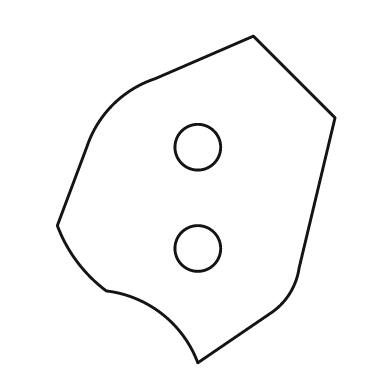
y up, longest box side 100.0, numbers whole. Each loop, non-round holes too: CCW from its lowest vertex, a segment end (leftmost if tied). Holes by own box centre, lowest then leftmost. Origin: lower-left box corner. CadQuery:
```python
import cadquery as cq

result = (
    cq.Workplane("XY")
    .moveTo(43.0, 0.0)
    .lineTo(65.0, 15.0)
    .threePointArc((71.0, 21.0), (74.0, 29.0))
    .lineTo(85.0, 75.0)
    .lineTo(60.0, 100.0)
    .lineTo(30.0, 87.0)
    .threePointArc((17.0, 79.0), (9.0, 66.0))
    .lineTo(0.0, 42.0)
    .threePointArc((6.0, 31.0), (15.0, 22.0))
    .threePointArc((32.0, 15.0), (43.0, 0.0))
    .close()
    .moveTo(43.0, 35.0)
    .circle(7.0)
    .moveTo(43.0, 66.0)
    .circle(7.0)
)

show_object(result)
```